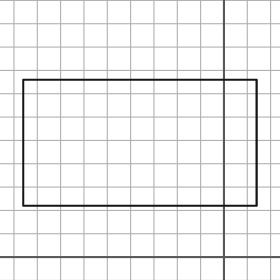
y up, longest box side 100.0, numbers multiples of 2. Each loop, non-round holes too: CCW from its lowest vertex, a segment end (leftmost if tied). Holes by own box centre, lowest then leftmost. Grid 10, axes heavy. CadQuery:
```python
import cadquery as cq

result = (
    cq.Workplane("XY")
    .moveTo(-86.0, 22.0)
    .lineTo(14.0, 22.0)
    .lineTo(14.0, 76.0)
    .lineTo(-86.0, 76.0)
    .close()
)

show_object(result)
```